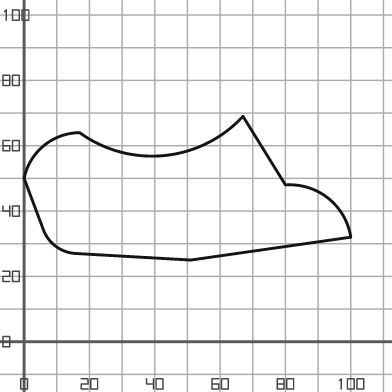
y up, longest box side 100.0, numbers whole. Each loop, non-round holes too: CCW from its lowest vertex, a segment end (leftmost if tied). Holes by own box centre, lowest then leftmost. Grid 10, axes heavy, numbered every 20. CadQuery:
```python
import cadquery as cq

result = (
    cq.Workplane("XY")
    .moveTo(51.0, 25.0)
    .lineTo(100.0, 32.0)
    .threePointArc((93.0, 44.0), (80.0, 48.0))
    .lineTo(67.0, 69.0)
    .threePointArc((43.0, 57.0), (17.0, 64.0))
    .threePointArc((6.0, 60.0), (0.0, 50.0))
    .lineTo(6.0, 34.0)
    .threePointArc((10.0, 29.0), (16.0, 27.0))
    .close()
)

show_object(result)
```